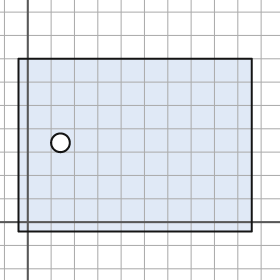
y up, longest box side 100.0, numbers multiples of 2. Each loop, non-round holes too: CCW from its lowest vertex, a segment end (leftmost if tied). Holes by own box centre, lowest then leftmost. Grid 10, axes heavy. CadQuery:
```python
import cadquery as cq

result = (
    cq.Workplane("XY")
    .moveTo(-4.0, -4.0)
    .lineTo(96.0, -4.0)
    .lineTo(96.0, 70.0)
    .lineTo(-4.0, 70.0)
    .close()
    .moveTo(14.0, 34.0)
    .circle(4.0)
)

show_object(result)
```